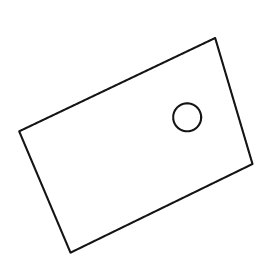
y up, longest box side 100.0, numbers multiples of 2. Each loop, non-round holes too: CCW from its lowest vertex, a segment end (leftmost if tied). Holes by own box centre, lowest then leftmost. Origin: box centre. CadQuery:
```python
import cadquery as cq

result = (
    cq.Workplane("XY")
    .moveTo(-28.0, -46.0)
    .lineTo(50.0, -8.0)
    .lineTo(34.0, 46.0)
    .lineTo(-50.0, 6.0)
    .close()
    .moveTo(22.0, 12.0)
    .circle(6.0)
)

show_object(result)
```